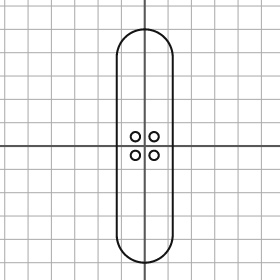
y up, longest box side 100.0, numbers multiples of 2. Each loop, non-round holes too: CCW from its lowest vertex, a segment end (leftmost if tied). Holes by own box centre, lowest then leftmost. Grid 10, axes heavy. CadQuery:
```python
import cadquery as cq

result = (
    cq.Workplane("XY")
    .moveTo(-12.0, -38.0)
    .threePointArc((0.0, -50.0), (12.0, -38.0))
    .lineTo(12.0, 38.0)
    .threePointArc((0.0, 50.0), (-12.0, 38.0))
    .close()
    .moveTo(-4.0, -4.0)
    .circle(2.0)
    .moveTo(4.0, -4.0)
    .circle(2.0)
    .moveTo(-4.0, 4.0)
    .circle(2.0)
    .moveTo(4.0, 4.0)
    .circle(2.0)
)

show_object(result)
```